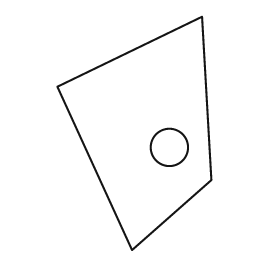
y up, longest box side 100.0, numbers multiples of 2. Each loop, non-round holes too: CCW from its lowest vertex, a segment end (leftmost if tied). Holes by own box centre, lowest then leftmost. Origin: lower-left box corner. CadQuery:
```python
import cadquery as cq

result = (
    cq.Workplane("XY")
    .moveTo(32.0, 0.0)
    .lineTo(66.0, 30.0)
    .lineTo(62.0, 100.0)
    .lineTo(0.0, 70.0)
    .close()
    .moveTo(48.0, 44.0)
    .circle(8.0)
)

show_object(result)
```